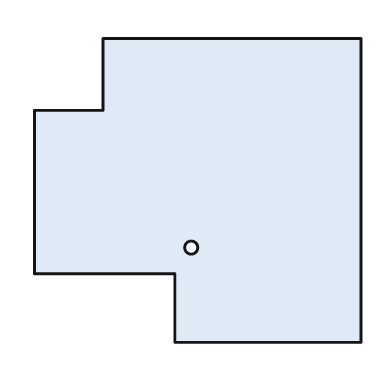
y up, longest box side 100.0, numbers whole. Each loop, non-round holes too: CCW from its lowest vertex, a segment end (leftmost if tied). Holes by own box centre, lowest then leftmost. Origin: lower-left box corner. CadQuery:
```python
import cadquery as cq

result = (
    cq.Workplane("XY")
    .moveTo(43.0, 0.0)
    .lineTo(100.0, 0.0)
    .lineTo(100.0, 93.0)
    .lineTo(21.0, 93.0)
    .lineTo(21.0, 71.0)
    .lineTo(0.0, 71.0)
    .lineTo(0.0, 21.0)
    .lineTo(43.0, 21.0)
    .close()
    .moveTo(48.0, 29.0)
    .circle(2.0)
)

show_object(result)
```